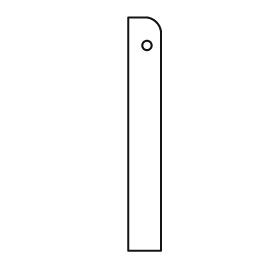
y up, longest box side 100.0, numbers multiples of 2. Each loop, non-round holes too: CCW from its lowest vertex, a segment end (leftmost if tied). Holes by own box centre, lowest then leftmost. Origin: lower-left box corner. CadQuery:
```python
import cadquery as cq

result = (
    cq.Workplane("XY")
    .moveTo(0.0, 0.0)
    .lineTo(14.0, 0.0)
    .lineTo(14.0, 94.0)
    .threePointArc((12.0, 98.0), (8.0, 100.0))
    .lineTo(0.0, 100.0)
    .close()
    .moveTo(8.0, 88.0)
    .circle(2.0)
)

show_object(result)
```